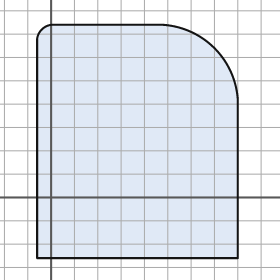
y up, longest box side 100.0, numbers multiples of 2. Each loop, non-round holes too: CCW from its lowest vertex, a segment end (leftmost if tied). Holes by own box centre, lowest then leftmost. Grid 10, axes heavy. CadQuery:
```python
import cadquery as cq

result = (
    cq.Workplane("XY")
    .moveTo(-6.0, -26.0)
    .lineTo(80.0, -26.0)
    .lineTo(80.0, 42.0)
    .threePointArc((70.0, 64.0), (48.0, 74.0))
    .lineTo(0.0, 74.0)
    .threePointArc((-4.0, 72.0), (-6.0, 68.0))
    .close()
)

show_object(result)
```